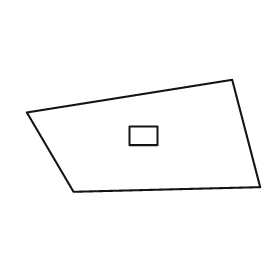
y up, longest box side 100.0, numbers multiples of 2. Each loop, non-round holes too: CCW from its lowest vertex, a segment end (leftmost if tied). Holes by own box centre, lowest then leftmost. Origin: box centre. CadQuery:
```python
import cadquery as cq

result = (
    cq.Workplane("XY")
    .moveTo(-30.0, -24.0)
    .lineTo(50.0, -22.0)
    .lineTo(38.0, 24.0)
    .lineTo(-50.0, 10.0)
    .close()
    .moveTo(-6.0, -4.0)
    .lineTo(6.0, -4.0)
    .lineTo(6.0, 4.0)
    .lineTo(-6.0, 4.0)
    .close()
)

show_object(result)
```